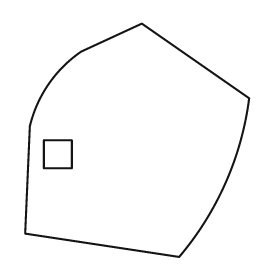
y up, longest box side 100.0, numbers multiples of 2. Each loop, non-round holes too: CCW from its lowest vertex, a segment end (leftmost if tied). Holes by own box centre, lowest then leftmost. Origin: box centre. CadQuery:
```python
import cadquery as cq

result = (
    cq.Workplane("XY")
    .moveTo(18.0, -50.0)
    .threePointArc((38.0, -18.0), (48.0, 18.0))
    .lineTo(2.0, 50.0)
    .lineTo(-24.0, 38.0)
    .threePointArc((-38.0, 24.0), (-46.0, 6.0))
    .lineTo(-48.0, -40.0)
    .close()
    .moveTo(-40.0, -12.0)
    .lineTo(-28.0, -12.0)
    .lineTo(-28.0, 0.0)
    .lineTo(-40.0, 0.0)
    .close()
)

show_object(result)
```